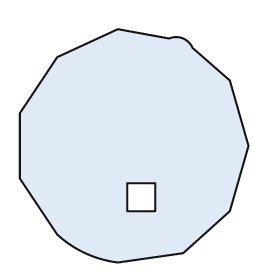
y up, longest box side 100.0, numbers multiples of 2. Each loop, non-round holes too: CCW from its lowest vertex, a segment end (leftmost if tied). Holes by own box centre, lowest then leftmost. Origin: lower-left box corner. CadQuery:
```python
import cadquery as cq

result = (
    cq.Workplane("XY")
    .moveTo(42.0, 0.0)
    .lineTo(70.0, 4.0)
    .lineTo(90.0, 22.0)
    .lineTo(98.0, 50.0)
    .lineTo(90.0, 78.0)
    .lineTo(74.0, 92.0)
    .threePointArc((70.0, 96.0), (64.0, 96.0))
    .lineTo(42.0, 100.0)
    .lineTo(16.0, 88.0)
    .lineTo(0.0, 64.0)
    .lineTo(0.0, 36.0)
    .lineTo(16.0, 12.0)
    .threePointArc((28.0, 4.0), (42.0, 0.0))
    .close()
    .moveTo(46.0, 22.0)
    .lineTo(58.0, 22.0)
    .lineTo(58.0, 34.0)
    .lineTo(46.0, 34.0)
    .close()
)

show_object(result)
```